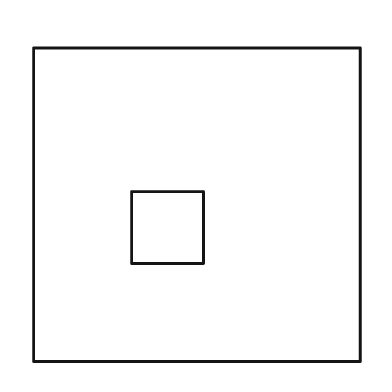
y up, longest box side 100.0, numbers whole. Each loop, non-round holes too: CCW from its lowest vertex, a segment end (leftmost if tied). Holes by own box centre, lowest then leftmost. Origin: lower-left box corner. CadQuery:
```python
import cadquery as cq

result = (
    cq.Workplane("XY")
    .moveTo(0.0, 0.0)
    .lineTo(100.0, 0.0)
    .lineTo(100.0, 96.0)
    .lineTo(0.0, 96.0)
    .close()
    .moveTo(30.0, 30.0)
    .lineTo(52.0, 30.0)
    .lineTo(52.0, 52.0)
    .lineTo(30.0, 52.0)
    .close()
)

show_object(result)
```